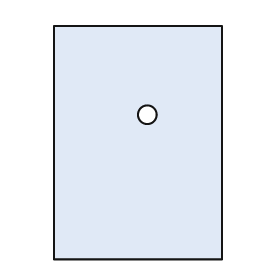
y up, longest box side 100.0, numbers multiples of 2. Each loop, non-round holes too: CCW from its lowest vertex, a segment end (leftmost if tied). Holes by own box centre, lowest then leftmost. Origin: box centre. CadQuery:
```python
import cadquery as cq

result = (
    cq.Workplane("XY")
    .moveTo(-36.0, -50.0)
    .lineTo(36.0, -50.0)
    .lineTo(36.0, 50.0)
    .lineTo(-36.0, 50.0)
    .close()
    .moveTo(4.0, 12.0)
    .circle(4.0)
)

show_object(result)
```